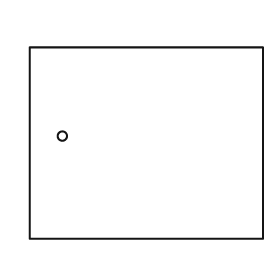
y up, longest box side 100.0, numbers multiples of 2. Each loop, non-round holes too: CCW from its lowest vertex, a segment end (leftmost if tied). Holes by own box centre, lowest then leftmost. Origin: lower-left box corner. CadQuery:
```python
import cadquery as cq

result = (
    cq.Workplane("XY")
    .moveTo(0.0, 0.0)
    .lineTo(100.0, 0.0)
    .lineTo(100.0, 82.0)
    .lineTo(0.0, 82.0)
    .close()
    .moveTo(14.0, 44.0)
    .circle(2.0)
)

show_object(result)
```